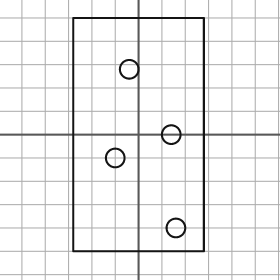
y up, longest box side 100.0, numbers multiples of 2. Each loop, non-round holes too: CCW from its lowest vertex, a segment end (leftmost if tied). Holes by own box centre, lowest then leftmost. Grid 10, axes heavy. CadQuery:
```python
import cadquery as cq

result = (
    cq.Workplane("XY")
    .moveTo(-28.0, -50.0)
    .lineTo(28.0, -50.0)
    .lineTo(28.0, 50.0)
    .lineTo(-28.0, 50.0)
    .close()
    .moveTo(16.0, -40.0)
    .circle(4.0)
    .moveTo(-10.0, -10.0)
    .circle(4.0)
    .moveTo(14.0, 0.0)
    .circle(4.0)
    .moveTo(-4.0, 28.0)
    .circle(4.0)
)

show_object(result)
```